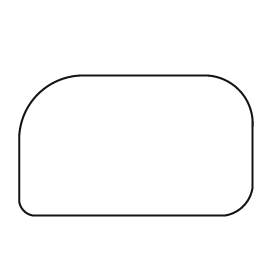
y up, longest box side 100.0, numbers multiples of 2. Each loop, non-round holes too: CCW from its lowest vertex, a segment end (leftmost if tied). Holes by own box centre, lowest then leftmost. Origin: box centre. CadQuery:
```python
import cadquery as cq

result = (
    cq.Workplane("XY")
    .moveTo(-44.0, -30.0)
    .lineTo(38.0, -30.0)
    .threePointArc((46.0, -26.0), (50.0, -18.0))
    .lineTo(50.0, 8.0)
    .threePointArc((44.0, 24.0), (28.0, 30.0))
    .lineTo(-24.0, 30.0)
    .threePointArc((-42.0, 22.0), (-50.0, 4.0))
    .lineTo(-50.0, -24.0)
    .threePointArc((-48.0, -28.0), (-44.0, -30.0))
    .close()
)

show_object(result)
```